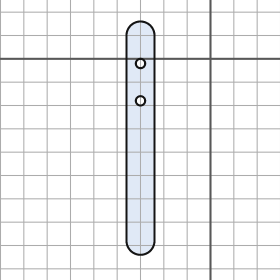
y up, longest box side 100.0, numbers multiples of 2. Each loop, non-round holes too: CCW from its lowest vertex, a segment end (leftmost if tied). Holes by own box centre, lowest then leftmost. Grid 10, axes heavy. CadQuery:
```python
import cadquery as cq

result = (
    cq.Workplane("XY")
    .moveTo(-36.0, -78.0)
    .threePointArc((-30.0, -84.0), (-24.0, -78.0))
    .lineTo(-24.0, 10.0)
    .threePointArc((-30.0, 16.0), (-36.0, 10.0))
    .close()
    .moveTo(-30.0, -18.0)
    .circle(2.0)
    .moveTo(-30.0, -2.0)
    .circle(2.0)
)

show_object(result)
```